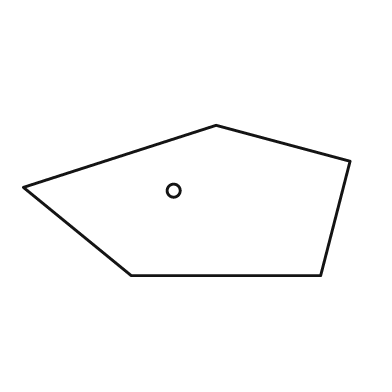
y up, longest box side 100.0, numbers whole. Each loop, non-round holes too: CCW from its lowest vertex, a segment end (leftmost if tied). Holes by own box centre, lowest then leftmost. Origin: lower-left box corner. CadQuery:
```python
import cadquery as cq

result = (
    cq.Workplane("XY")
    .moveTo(33.0, 0.0)
    .lineTo(91.0, 0.0)
    .lineTo(100.0, 35.0)
    .lineTo(59.0, 46.0)
    .lineTo(0.0, 27.0)
    .close()
    .moveTo(46.0, 26.0)
    .circle(2.0)
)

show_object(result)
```